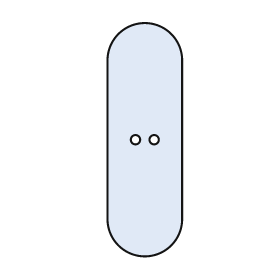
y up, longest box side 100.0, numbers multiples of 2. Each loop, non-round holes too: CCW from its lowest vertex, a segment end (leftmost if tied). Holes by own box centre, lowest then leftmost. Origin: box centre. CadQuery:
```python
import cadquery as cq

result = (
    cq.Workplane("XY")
    .moveTo(-16.0, -34.0)
    .threePointArc((0.0, -50.0), (16.0, -34.0))
    .lineTo(16.0, 34.0)
    .threePointArc((0.0, 50.0), (-16.0, 34.0))
    .close()
    .moveTo(-4.0, 0.0)
    .circle(2.0)
    .moveTo(4.0, 0.0)
    .circle(2.0)
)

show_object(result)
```